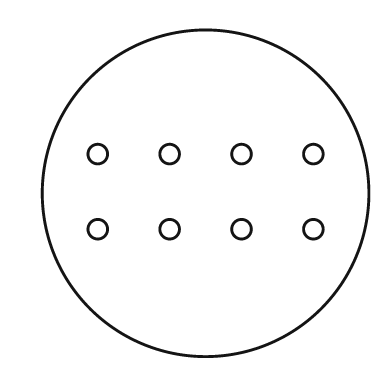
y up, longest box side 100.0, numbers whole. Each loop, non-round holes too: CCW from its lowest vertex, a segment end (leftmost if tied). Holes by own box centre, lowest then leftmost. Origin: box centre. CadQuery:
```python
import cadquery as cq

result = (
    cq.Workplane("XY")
    .moveTo(0.0, 0.0)
    .circle(50.0)
    .moveTo(-33.0, -11.0)
    .circle(3.0)
    .moveTo(-11.0, -11.0)
    .circle(3.0)
    .moveTo(11.0, -11.0)
    .circle(3.0)
    .moveTo(33.0, -11.0)
    .circle(3.0)
    .moveTo(-33.0, 12.0)
    .circle(3.0)
    .moveTo(-11.0, 12.0)
    .circle(3.0)
    .moveTo(11.0, 12.0)
    .circle(3.0)
    .moveTo(33.0, 12.0)
    .circle(3.0)
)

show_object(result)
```